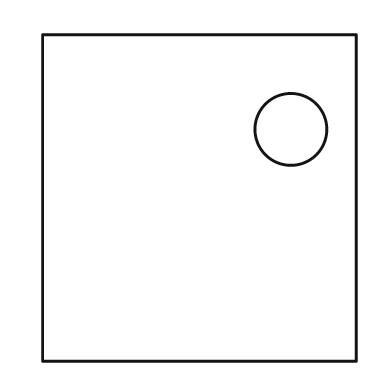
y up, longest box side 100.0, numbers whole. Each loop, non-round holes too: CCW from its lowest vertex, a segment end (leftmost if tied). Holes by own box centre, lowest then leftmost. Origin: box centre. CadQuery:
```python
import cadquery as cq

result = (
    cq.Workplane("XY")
    .moveTo(-48.0, -50.0)
    .lineTo(48.0, -50.0)
    .lineTo(48.0, 50.0)
    .lineTo(-48.0, 50.0)
    .close()
    .moveTo(28.0, 21.0)
    .circle(11.0)
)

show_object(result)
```